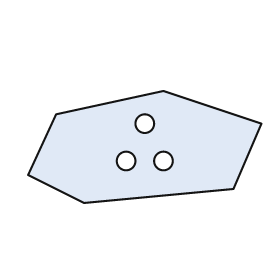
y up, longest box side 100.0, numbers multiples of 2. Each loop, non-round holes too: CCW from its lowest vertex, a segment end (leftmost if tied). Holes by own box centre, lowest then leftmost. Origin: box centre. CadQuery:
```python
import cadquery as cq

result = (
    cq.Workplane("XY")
    .moveTo(-26.0, -24.0)
    .lineTo(38.0, -18.0)
    .lineTo(50.0, 10.0)
    .lineTo(8.0, 24.0)
    .lineTo(-38.0, 14.0)
    .lineTo(-50.0, -12.0)
    .close()
    .moveTo(-8.0, -6.0)
    .circle(4.0)
    .moveTo(8.0, -6.0)
    .circle(4.0)
    .moveTo(0.0, 10.0)
    .circle(4.0)
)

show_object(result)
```